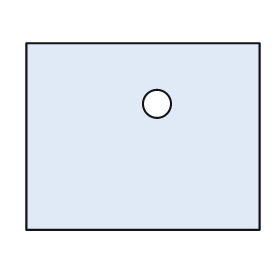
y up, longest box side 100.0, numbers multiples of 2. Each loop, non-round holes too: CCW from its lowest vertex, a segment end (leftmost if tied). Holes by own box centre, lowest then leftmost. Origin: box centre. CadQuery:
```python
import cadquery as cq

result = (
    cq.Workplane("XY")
    .moveTo(-50.0, -40.0)
    .lineTo(50.0, -40.0)
    .lineTo(50.0, 40.0)
    .lineTo(-50.0, 40.0)
    .close()
    .moveTo(6.0, 14.0)
    .circle(6.0)
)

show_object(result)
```